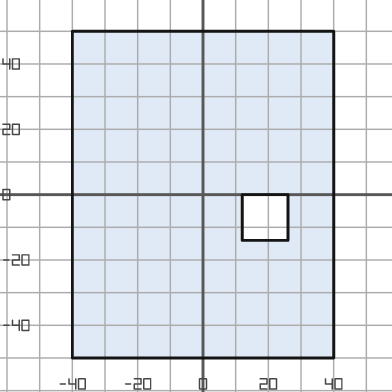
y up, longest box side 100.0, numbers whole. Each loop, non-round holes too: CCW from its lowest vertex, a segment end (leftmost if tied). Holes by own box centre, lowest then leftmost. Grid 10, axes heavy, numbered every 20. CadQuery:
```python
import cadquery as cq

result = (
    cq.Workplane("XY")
    .moveTo(-40.0, -50.0)
    .lineTo(40.0, -50.0)
    .lineTo(40.0, 50.0)
    .lineTo(-40.0, 50.0)
    .close()
    .moveTo(12.0, -14.0)
    .lineTo(26.0, -14.0)
    .lineTo(26.0, 0.0)
    .lineTo(12.0, 0.0)
    .close()
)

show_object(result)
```